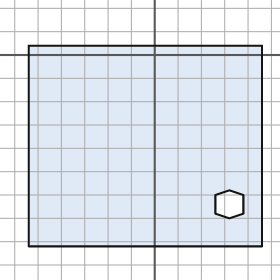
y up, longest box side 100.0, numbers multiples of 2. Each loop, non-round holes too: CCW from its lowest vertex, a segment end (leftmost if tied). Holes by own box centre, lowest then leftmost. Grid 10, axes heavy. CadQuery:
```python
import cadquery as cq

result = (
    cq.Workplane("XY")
    .moveTo(-54.0, -82.0)
    .lineTo(46.0, -82.0)
    .lineTo(46.0, 4.0)
    .lineTo(-54.0, 4.0)
    .close()
    .moveTo(32.0, -70.0)
    .lineTo(38.0, -68.0)
    .lineTo(38.0, -60.0)
    .lineTo(32.0, -58.0)
    .lineTo(26.0, -60.0)
    .lineTo(26.0, -68.0)
    .close()
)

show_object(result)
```